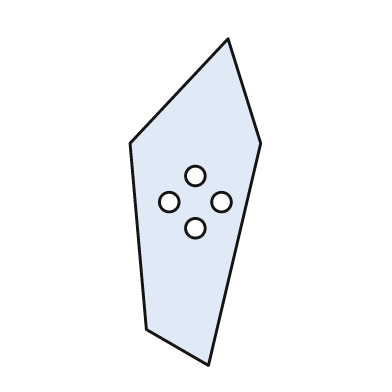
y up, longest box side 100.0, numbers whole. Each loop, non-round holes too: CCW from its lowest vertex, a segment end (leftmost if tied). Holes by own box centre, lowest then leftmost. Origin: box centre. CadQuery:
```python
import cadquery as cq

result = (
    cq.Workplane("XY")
    .moveTo(4.0, -50.0)
    .lineTo(20.0, 18.0)
    .lineTo(10.0, 50.0)
    .lineTo(-20.0, 18.0)
    .lineTo(-15.0, -39.0)
    .close()
    .moveTo(0.0, -8.0)
    .circle(3.0)
    .moveTo(-8.0, 0.0)
    .circle(3.0)
    .moveTo(8.0, 0.0)
    .circle(3.0)
    .moveTo(0.0, 8.0)
    .circle(3.0)
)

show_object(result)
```